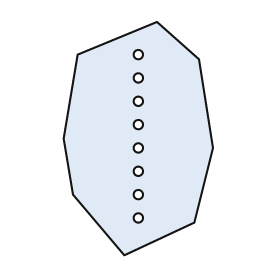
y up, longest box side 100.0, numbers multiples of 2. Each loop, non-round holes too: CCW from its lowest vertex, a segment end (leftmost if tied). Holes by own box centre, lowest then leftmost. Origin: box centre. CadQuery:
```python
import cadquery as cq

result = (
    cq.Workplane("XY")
    .moveTo(-6.0, -50.0)
    .lineTo(24.0, -36.0)
    .lineTo(32.0, -4.0)
    .lineTo(26.0, 34.0)
    .lineTo(8.0, 50.0)
    .lineTo(-26.0, 36.0)
    .lineTo(-32.0, 0.0)
    .lineTo(-28.0, -24.0)
    .close()
    .moveTo(0.0, -34.0)
    .circle(2.0)
    .moveTo(0.0, -24.0)
    .circle(2.0)
    .moveTo(0.0, -14.0)
    .circle(2.0)
    .moveTo(0.0, -4.0)
    .circle(2.0)
    .moveTo(0.0, 6.0)
    .circle(2.0)
    .moveTo(0.0, 16.0)
    .circle(2.0)
    .moveTo(0.0, 26.0)
    .circle(2.0)
    .moveTo(0.0, 36.0)
    .circle(2.0)
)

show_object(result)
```